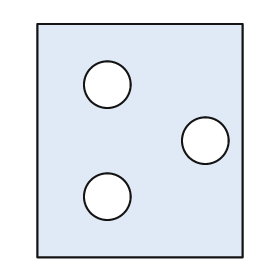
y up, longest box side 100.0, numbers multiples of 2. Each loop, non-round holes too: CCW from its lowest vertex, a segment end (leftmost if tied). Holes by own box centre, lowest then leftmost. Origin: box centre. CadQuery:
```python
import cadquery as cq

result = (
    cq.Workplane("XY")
    .moveTo(-44.0, -50.0)
    .lineTo(44.0, -50.0)
    .lineTo(44.0, 50.0)
    .lineTo(-44.0, 50.0)
    .close()
    .moveTo(-14.0, -24.0)
    .circle(10.0)
    .moveTo(28.0, 0.0)
    .circle(10.0)
    .moveTo(-14.0, 24.0)
    .circle(10.0)
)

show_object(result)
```